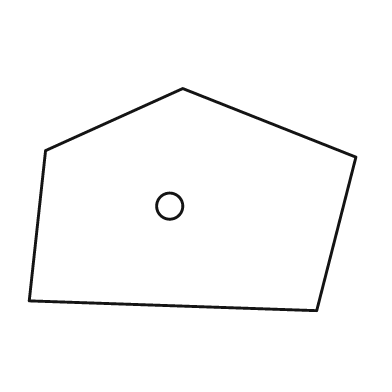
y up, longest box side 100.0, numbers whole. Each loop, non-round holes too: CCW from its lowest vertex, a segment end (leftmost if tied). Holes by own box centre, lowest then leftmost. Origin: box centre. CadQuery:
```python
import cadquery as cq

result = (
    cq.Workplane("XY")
    .moveTo(38.0, -34.0)
    .lineTo(50.0, 13.0)
    .lineTo(-3.0, 34.0)
    .lineTo(-45.0, 15.0)
    .lineTo(-50.0, -31.0)
    .close()
    .moveTo(-7.0, -2.0)
    .circle(4.0)
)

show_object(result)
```